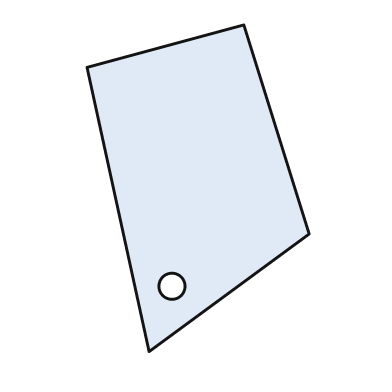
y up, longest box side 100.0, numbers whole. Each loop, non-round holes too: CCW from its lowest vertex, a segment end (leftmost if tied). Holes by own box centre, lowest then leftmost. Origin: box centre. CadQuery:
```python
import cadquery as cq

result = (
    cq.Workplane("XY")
    .moveTo(-15.0, -50.0)
    .lineTo(34.0, -14.0)
    .lineTo(14.0, 50.0)
    .lineTo(-34.0, 37.0)
    .close()
    .moveTo(-8.0, -30.0)
    .circle(4.0)
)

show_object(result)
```